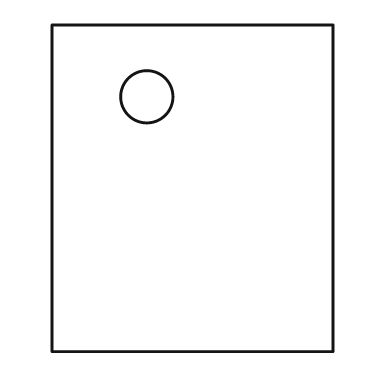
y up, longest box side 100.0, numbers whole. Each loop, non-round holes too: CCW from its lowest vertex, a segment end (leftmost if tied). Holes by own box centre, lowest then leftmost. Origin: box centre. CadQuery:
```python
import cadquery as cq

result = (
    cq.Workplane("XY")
    .moveTo(-43.0, -50.0)
    .lineTo(43.0, -50.0)
    .lineTo(43.0, 50.0)
    .lineTo(-43.0, 50.0)
    .close()
    .moveTo(-14.0, 28.0)
    .circle(8.0)
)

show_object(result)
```